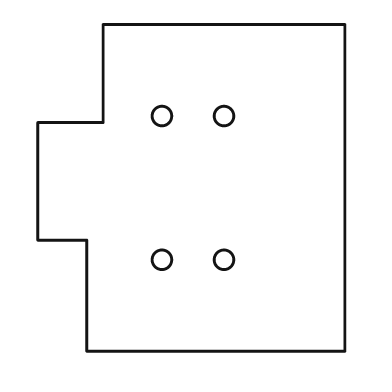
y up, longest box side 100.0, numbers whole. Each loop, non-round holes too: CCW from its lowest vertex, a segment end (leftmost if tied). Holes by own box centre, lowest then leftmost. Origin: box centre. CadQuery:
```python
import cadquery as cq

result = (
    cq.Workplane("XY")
    .moveTo(-32.0, -50.0)
    .lineTo(47.0, -50.0)
    .lineTo(47.0, 50.0)
    .lineTo(-27.0, 50.0)
    .lineTo(-27.0, 20.0)
    .lineTo(-47.0, 20.0)
    .lineTo(-47.0, -16.0)
    .lineTo(-32.0, -16.0)
    .close()
    .moveTo(-9.0, -22.0)
    .circle(3.0)
    .moveTo(10.0, -22.0)
    .circle(3.0)
    .moveTo(-9.0, 22.0)
    .circle(3.0)
    .moveTo(10.0, 22.0)
    .circle(3.0)
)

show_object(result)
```